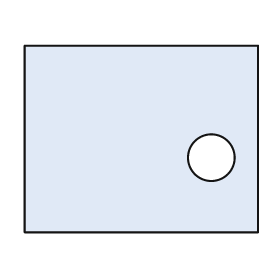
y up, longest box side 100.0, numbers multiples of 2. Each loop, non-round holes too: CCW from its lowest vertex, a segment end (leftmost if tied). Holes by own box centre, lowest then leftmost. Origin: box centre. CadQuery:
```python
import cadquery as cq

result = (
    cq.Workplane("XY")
    .moveTo(-50.0, -40.0)
    .lineTo(50.0, -40.0)
    .lineTo(50.0, 40.0)
    .lineTo(-50.0, 40.0)
    .close()
    .moveTo(30.0, -8.0)
    .circle(10.0)
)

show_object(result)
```